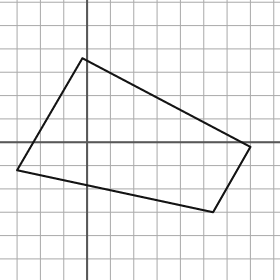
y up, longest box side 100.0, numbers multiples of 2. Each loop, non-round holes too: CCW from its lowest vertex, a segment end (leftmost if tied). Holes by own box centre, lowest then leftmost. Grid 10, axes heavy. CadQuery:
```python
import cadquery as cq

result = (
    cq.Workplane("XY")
    .moveTo(54.0, -30.0)
    .lineTo(70.0, -2.0)
    .lineTo(-2.0, 36.0)
    .lineTo(-30.0, -12.0)
    .close()
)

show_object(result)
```